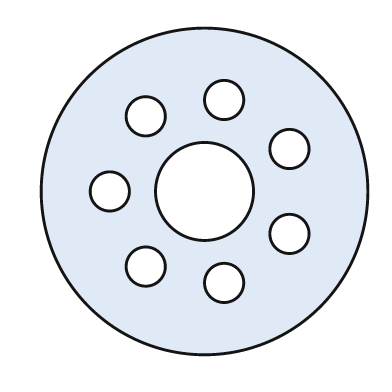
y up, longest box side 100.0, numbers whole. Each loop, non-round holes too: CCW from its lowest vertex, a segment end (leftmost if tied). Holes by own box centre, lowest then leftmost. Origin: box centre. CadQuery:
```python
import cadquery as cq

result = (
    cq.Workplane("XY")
    .moveTo(0.0, 0.0)
    .circle(50.0)
    .moveTo(6.0, -28.0)
    .circle(6.0)
    .moveTo(-18.0, -23.0)
    .circle(6.0)
    .moveTo(26.0, -13.0)
    .circle(6.0)
    .moveTo(-29.0, 0.0)
    .circle(6.0)
    .moveTo(0.0, 0.0)
    .circle(15.0)
    .moveTo(26.0, 13.0)
    .circle(6.0)
    .moveTo(-18.0, 23.0)
    .circle(6.0)
    .moveTo(6.0, 28.0)
    .circle(6.0)
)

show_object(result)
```